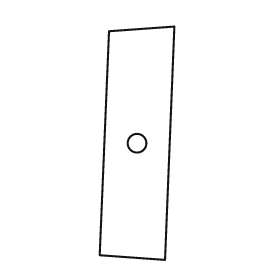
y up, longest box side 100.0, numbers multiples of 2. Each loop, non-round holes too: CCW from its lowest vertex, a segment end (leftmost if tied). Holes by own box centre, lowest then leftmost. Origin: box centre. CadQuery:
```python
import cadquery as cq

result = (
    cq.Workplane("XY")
    .moveTo(12.0, -50.0)
    .lineTo(16.0, 50.0)
    .lineTo(-12.0, 48.0)
    .lineTo(-16.0, -48.0)
    .close()
    .moveTo(0.0, 0.0)
    .circle(4.0)
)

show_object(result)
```